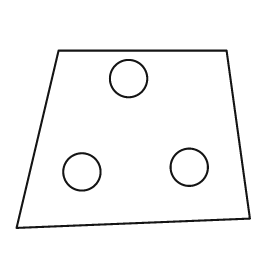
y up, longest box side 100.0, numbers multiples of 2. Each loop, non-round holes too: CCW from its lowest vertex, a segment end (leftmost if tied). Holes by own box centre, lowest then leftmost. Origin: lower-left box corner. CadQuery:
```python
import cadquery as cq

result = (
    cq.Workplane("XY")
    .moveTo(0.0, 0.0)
    .lineTo(100.0, 4.0)
    .lineTo(90.0, 76.0)
    .lineTo(18.0, 76.0)
    .close()
    .moveTo(28.0, 24.0)
    .circle(8.0)
    .moveTo(74.0, 26.0)
    .circle(8.0)
    .moveTo(48.0, 64.0)
    .circle(8.0)
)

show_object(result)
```